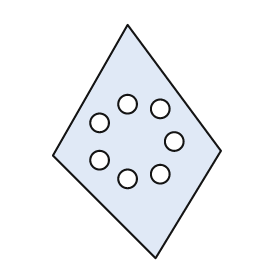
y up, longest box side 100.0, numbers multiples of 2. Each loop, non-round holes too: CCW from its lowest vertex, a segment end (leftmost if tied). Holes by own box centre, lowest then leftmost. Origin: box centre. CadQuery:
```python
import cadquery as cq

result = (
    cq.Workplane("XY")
    .moveTo(8.0, -50.0)
    .lineTo(36.0, -4.0)
    .lineTo(-4.0, 50.0)
    .lineTo(-36.0, -6.0)
    .close()
    .moveTo(-4.0, -16.0)
    .circle(4.0)
    .moveTo(10.0, -14.0)
    .circle(4.0)
    .moveTo(-16.0, -8.0)
    .circle(4.0)
    .moveTo(16.0, 0.0)
    .circle(4.0)
    .moveTo(-16.0, 8.0)
    .circle(4.0)
    .moveTo(10.0, 14.0)
    .circle(4.0)
    .moveTo(-4.0, 16.0)
    .circle(4.0)
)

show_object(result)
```